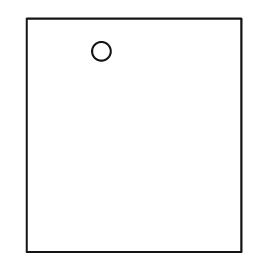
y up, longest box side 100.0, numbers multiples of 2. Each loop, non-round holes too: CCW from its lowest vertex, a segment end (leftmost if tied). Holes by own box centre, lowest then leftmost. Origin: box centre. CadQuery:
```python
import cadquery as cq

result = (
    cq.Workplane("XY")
    .moveTo(-46.0, -50.0)
    .lineTo(46.0, -50.0)
    .lineTo(46.0, 50.0)
    .lineTo(-46.0, 50.0)
    .close()
    .moveTo(-14.0, 36.0)
    .circle(4.0)
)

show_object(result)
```